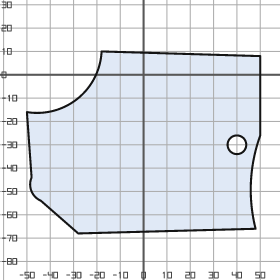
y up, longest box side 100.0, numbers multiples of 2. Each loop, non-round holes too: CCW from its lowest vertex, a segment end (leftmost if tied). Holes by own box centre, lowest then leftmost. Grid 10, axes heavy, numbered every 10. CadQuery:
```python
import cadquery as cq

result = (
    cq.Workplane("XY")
    .moveTo(-28.0, -68.0)
    .lineTo(48.0, -66.0)
    .threePointArc((46.0, -46.0), (50.0, -26.0))
    .lineTo(50.0, 8.0)
    .lineTo(-18.0, 10.0)
    .threePointArc((-28.0, -10.0), (-50.0, -16.0))
    .lineTo(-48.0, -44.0)
    .threePointArc((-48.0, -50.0), (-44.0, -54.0))
    .close()
    .moveTo(40.0, -30.0)
    .circle(4.0)
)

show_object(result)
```